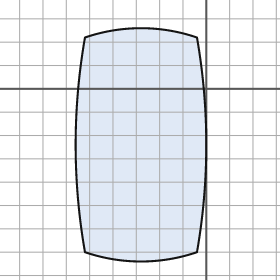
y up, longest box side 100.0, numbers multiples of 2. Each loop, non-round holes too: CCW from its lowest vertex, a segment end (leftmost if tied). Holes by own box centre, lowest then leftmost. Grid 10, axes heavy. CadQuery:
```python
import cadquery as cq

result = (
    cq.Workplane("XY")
    .moveTo(-52.0, -70.0)
    .threePointArc((-28.0, -74.0), (-4.0, -70.0))
    .threePointArc((0.0, -24.0), (-4.0, 22.0))
    .threePointArc((-28.0, 26.0), (-52.0, 22.0))
    .threePointArc((-56.0, -24.0), (-52.0, -70.0))
    .close()
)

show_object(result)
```